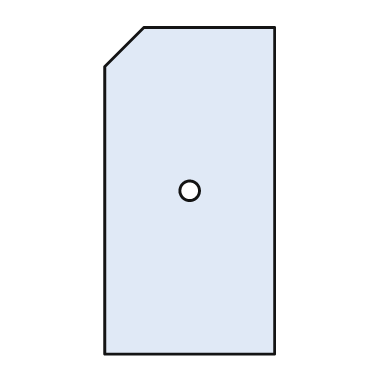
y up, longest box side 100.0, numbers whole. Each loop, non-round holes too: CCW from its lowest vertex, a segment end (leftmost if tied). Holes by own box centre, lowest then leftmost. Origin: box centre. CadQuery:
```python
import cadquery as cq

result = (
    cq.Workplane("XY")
    .moveTo(-26.0, -50.0)
    .lineTo(26.0, -50.0)
    .lineTo(26.0, 50.0)
    .lineTo(-14.0, 50.0)
    .lineTo(-26.0, 38.0)
    .close()
    .moveTo(0.0, 0.0)
    .circle(3.0)
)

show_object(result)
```